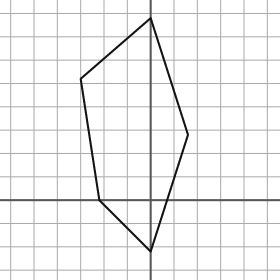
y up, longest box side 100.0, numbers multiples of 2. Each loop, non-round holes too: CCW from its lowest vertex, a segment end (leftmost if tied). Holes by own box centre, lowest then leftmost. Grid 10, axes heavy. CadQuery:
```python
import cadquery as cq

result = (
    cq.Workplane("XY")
    .moveTo(0.0, -22.0)
    .lineTo(16.0, 28.0)
    .lineTo(0.0, 78.0)
    .lineTo(-30.0, 52.0)
    .lineTo(-22.0, 0.0)
    .close()
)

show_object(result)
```